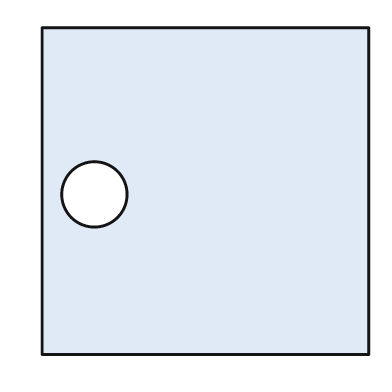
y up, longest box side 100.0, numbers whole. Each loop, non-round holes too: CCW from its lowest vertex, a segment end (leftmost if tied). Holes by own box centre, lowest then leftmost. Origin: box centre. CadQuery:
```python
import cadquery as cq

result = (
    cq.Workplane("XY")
    .moveTo(-50.0, -50.0)
    .lineTo(50.0, -50.0)
    .lineTo(50.0, 50.0)
    .lineTo(-50.0, 50.0)
    .close()
    .moveTo(-34.0, -1.0)
    .circle(10.0)
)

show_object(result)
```